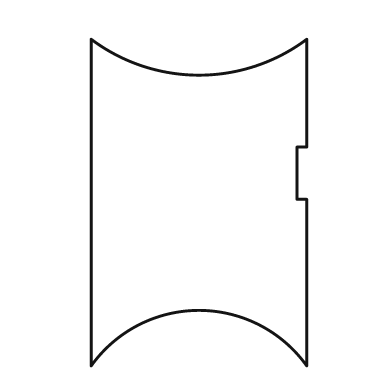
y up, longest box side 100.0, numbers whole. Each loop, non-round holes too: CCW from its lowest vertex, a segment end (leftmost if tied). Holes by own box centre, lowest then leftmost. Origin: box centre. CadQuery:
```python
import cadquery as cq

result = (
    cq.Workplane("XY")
    .moveTo(-33.0, -50.0)
    .threePointArc((0.0, -33.0), (33.0, -50.0))
    .lineTo(33.0, 1.0)
    .lineTo(30.0, 1.0)
    .lineTo(30.0, 17.0)
    .lineTo(33.0, 17.0)
    .lineTo(33.0, 50.0)
    .threePointArc((0.0, 39.0), (-33.0, 50.0))
    .close()
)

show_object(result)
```